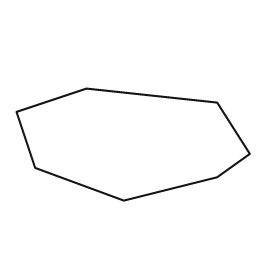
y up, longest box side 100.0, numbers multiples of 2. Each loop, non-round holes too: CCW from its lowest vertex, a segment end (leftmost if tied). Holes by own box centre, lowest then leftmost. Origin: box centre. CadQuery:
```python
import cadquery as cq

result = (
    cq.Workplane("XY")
    .moveTo(-4.0, -24.0)
    .lineTo(36.0, -14.0)
    .lineTo(50.0, -4.0)
    .lineTo(36.0, 18.0)
    .lineTo(-20.0, 24.0)
    .lineTo(-50.0, 14.0)
    .lineTo(-42.0, -10.0)
    .close()
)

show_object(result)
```